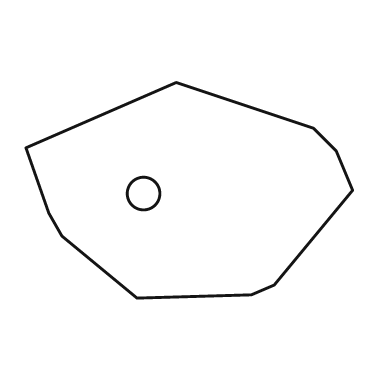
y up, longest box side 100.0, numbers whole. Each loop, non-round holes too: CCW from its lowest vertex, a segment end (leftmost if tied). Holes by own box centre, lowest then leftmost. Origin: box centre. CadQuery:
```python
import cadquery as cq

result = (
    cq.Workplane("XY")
    .moveTo(-16.0, -33.0)
    .lineTo(19.0, -32.0)
    .lineTo(26.0, -29.0)
    .lineTo(50.0, 0.0)
    .lineTo(45.0, 12.0)
    .lineTo(38.0, 19.0)
    .lineTo(-4.0, 33.0)
    .lineTo(-50.0, 13.0)
    .lineTo(-43.0, -7.0)
    .lineTo(-39.0, -14.0)
    .close()
    .moveTo(-14.0, -1.0)
    .circle(5.0)
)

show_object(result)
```